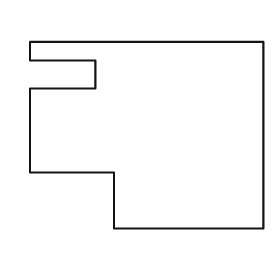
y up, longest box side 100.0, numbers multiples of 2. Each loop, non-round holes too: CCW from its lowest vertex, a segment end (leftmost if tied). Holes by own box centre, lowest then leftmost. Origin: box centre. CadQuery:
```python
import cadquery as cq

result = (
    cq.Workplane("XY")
    .moveTo(-14.0, -40.0)
    .lineTo(50.0, -40.0)
    .lineTo(50.0, 40.0)
    .lineTo(-50.0, 40.0)
    .lineTo(-50.0, 32.0)
    .lineTo(-22.0, 32.0)
    .lineTo(-22.0, 20.0)
    .lineTo(-50.0, 20.0)
    .lineTo(-50.0, -16.0)
    .lineTo(-14.0, -16.0)
    .close()
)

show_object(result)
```